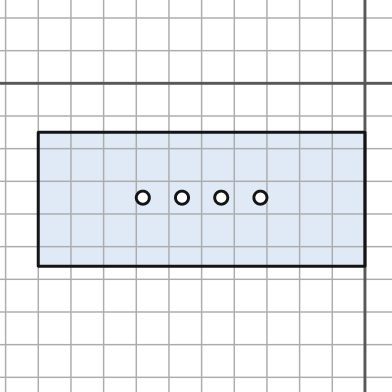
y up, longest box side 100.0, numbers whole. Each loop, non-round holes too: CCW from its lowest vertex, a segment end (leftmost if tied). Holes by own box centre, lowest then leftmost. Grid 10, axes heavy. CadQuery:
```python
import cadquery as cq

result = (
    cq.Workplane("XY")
    .moveTo(-100.0, -56.0)
    .lineTo(0.0, -56.0)
    .lineTo(0.0, -15.0)
    .lineTo(-100.0, -15.0)
    .close()
    .moveTo(-68.0, -35.0)
    .circle(2.0)
    .moveTo(-56.0, -35.0)
    .circle(2.0)
    .moveTo(-44.0, -35.0)
    .circle(2.0)
    .moveTo(-32.0, -35.0)
    .circle(2.0)
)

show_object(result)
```